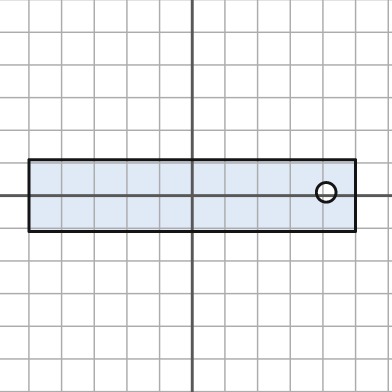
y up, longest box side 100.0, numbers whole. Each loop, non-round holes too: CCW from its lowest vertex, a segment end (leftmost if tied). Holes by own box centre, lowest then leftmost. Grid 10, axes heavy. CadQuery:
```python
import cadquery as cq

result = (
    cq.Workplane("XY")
    .moveTo(-50.0, -11.0)
    .lineTo(50.0, -11.0)
    .lineTo(50.0, 11.0)
    .lineTo(-50.0, 11.0)
    .close()
    .moveTo(41.0, 1.0)
    .circle(3.0)
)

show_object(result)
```